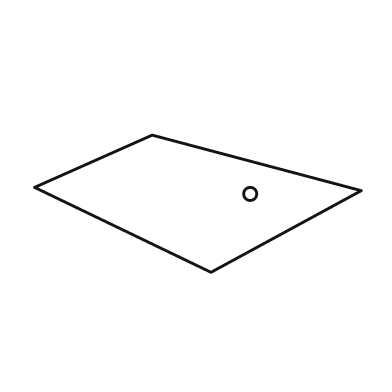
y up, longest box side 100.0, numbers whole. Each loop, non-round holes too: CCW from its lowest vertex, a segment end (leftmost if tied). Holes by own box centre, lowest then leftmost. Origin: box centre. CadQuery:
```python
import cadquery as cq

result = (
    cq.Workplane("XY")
    .moveTo(4.0, -21.0)
    .lineTo(50.0, 4.0)
    .lineTo(-14.0, 21.0)
    .lineTo(-50.0, 5.0)
    .close()
    .moveTo(16.0, 3.0)
    .circle(2.0)
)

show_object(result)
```